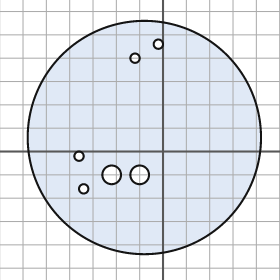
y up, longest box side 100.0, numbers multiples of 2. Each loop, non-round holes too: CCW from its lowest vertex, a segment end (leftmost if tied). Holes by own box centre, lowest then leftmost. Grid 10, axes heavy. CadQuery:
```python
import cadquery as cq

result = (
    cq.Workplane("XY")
    .moveTo(-8.0, 6.0)
    .circle(50.0)
    .moveTo(-34.0, -16.0)
    .circle(2.0)
    .moveTo(-22.0, -10.0)
    .circle(4.0)
    .moveTo(-10.0, -10.0)
    .circle(4.0)
    .moveTo(-36.0, -2.0)
    .circle(2.0)
    .moveTo(-12.0, 40.0)
    .circle(2.0)
    .moveTo(-2.0, 46.0)
    .circle(2.0)
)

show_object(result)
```